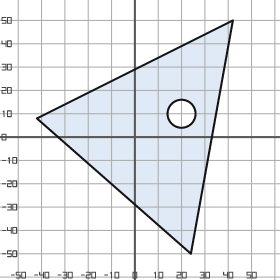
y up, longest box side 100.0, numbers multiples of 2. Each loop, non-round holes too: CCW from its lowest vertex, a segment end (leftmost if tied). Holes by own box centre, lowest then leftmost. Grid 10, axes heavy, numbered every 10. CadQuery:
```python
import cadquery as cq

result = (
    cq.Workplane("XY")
    .moveTo(24.0, -50.0)
    .lineTo(42.0, 50.0)
    .lineTo(-42.0, 8.0)
    .close()
    .moveTo(20.0, 10.0)
    .circle(6.0)
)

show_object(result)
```